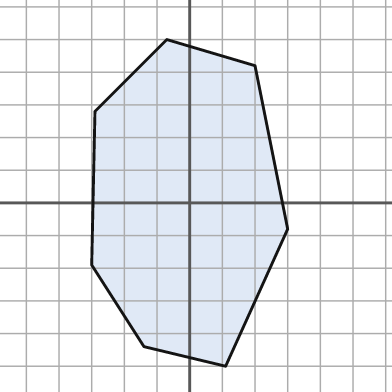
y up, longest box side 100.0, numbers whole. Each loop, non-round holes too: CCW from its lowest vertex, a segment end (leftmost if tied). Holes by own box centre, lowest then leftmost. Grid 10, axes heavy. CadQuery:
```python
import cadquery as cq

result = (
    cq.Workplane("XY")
    .moveTo(11.0, -50.0)
    .lineTo(30.0, -8.0)
    .lineTo(20.0, 42.0)
    .lineTo(-7.0, 50.0)
    .lineTo(-29.0, 28.0)
    .lineTo(-30.0, -19.0)
    .lineTo(-14.0, -44.0)
    .close()
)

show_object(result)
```